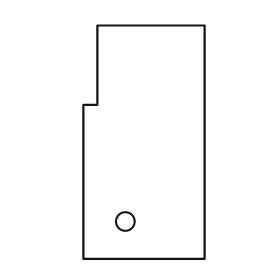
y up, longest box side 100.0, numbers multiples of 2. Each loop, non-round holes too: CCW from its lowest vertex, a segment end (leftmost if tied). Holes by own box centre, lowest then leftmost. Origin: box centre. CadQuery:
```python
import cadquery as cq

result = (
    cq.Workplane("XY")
    .moveTo(-26.0, -50.0)
    .lineTo(26.0, -50.0)
    .lineTo(26.0, 50.0)
    .lineTo(-20.0, 50.0)
    .lineTo(-20.0, 16.0)
    .lineTo(-26.0, 16.0)
    .close()
    .moveTo(-8.0, -34.0)
    .circle(4.0)
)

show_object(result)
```